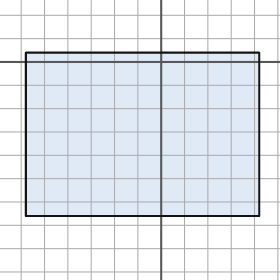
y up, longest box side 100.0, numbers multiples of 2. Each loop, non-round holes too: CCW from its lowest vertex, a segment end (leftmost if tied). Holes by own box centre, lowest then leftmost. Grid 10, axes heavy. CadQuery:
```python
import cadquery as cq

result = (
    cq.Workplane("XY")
    .moveTo(-58.0, -66.0)
    .lineTo(42.0, -66.0)
    .lineTo(42.0, 4.0)
    .lineTo(-58.0, 4.0)
    .close()
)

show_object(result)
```